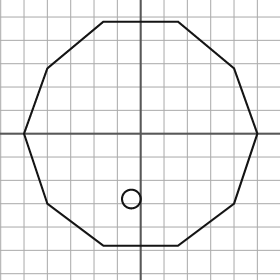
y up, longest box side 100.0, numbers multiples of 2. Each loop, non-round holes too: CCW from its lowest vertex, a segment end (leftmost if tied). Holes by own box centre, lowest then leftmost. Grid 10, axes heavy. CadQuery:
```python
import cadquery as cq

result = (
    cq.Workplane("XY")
    .moveTo(-16.0, -48.0)
    .lineTo(16.0, -48.0)
    .lineTo(40.0, -30.0)
    .lineTo(50.0, 0.0)
    .lineTo(40.0, 28.0)
    .lineTo(16.0, 48.0)
    .lineTo(-16.0, 48.0)
    .lineTo(-40.0, 28.0)
    .lineTo(-50.0, 0.0)
    .lineTo(-40.0, -30.0)
    .close()
    .moveTo(-4.0, -28.0)
    .circle(4.0)
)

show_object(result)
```